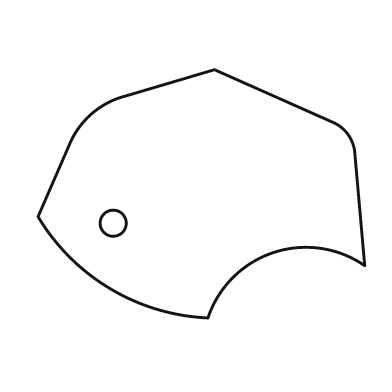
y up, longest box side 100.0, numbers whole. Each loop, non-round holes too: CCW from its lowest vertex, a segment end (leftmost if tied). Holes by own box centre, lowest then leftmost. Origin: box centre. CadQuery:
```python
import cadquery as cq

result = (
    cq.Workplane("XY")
    .moveTo(2.0, -38.0)
    .threePointArc((22.0, -18.0), (50.0, -22.0))
    .lineTo(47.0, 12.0)
    .threePointArc((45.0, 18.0), (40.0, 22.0))
    .lineTo(4.0, 38.0)
    .lineTo(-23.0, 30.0)
    .threePointArc((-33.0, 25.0), (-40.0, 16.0))
    .lineTo(-50.0, -7.0)
    .threePointArc((-28.0, -29.0), (2.0, -38.0))
    .close()
    .moveTo(-27.0, -9.0)
    .circle(4.0)
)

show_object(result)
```